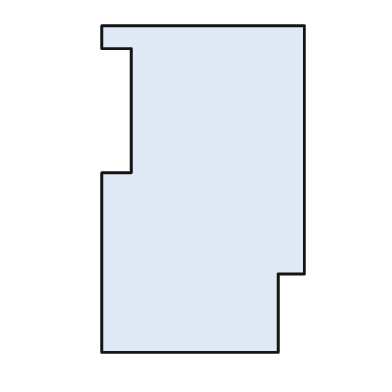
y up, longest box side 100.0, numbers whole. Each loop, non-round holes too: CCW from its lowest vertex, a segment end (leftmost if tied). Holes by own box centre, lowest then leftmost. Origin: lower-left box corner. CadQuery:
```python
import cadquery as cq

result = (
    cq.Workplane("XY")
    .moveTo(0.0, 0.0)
    .lineTo(54.0, 0.0)
    .lineTo(54.0, 24.0)
    .lineTo(62.0, 24.0)
    .lineTo(62.0, 100.0)
    .lineTo(0.0, 100.0)
    .lineTo(0.0, 93.0)
    .lineTo(9.0, 93.0)
    .lineTo(9.0, 55.0)
    .lineTo(0.0, 55.0)
    .close()
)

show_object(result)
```